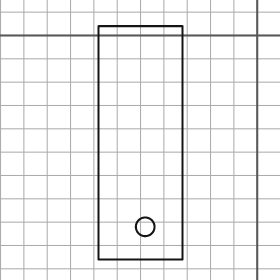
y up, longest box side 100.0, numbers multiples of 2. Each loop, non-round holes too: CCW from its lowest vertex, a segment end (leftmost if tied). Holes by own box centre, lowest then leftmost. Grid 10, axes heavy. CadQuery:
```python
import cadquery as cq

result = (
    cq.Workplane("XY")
    .moveTo(-68.0, -96.0)
    .lineTo(-32.0, -96.0)
    .lineTo(-32.0, 4.0)
    .lineTo(-68.0, 4.0)
    .close()
    .moveTo(-48.0, -82.0)
    .circle(4.0)
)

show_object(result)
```